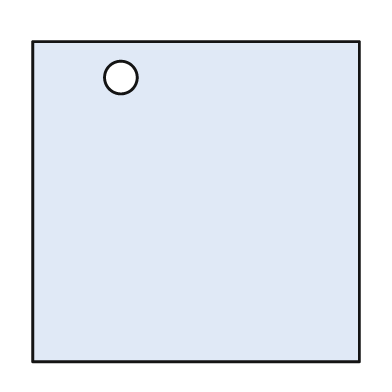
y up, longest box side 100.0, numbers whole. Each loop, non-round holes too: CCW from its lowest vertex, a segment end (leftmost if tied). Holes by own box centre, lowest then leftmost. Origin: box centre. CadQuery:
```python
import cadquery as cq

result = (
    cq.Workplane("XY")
    .moveTo(-50.0, -49.0)
    .lineTo(50.0, -49.0)
    .lineTo(50.0, 49.0)
    .lineTo(-50.0, 49.0)
    .close()
    .moveTo(-23.0, 38.0)
    .circle(5.0)
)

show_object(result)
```